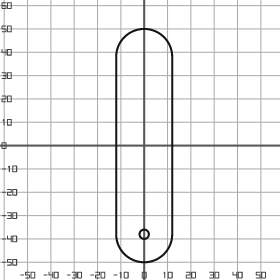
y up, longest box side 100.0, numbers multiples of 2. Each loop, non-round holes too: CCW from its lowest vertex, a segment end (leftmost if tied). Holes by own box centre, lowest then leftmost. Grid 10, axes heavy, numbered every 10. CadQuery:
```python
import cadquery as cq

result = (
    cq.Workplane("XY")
    .moveTo(-12.0, -38.0)
    .threePointArc((0.0, -50.0), (12.0, -38.0))
    .lineTo(12.0, 38.0)
    .threePointArc((0.0, 50.0), (-12.0, 38.0))
    .close()
    .moveTo(0.0, -38.0)
    .circle(2.0)
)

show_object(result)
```